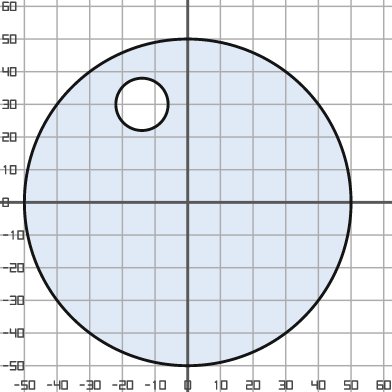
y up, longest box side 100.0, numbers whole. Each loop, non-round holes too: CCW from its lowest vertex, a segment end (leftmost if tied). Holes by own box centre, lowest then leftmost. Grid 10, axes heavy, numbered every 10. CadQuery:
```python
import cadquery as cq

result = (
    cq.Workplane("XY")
    .moveTo(0.0, 0.0)
    .circle(50.0)
    .moveTo(-14.0, 30.0)
    .circle(8.0)
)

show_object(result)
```